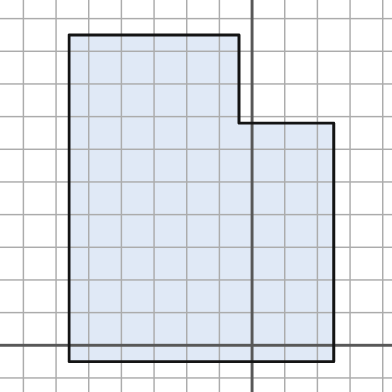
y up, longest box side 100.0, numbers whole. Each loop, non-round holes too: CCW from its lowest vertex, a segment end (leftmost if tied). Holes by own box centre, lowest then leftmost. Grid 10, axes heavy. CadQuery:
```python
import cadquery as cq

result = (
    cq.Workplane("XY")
    .moveTo(-56.0, -5.0)
    .lineTo(25.0, -5.0)
    .lineTo(25.0, 68.0)
    .lineTo(-4.0, 68.0)
    .lineTo(-4.0, 95.0)
    .lineTo(-56.0, 95.0)
    .close()
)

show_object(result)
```